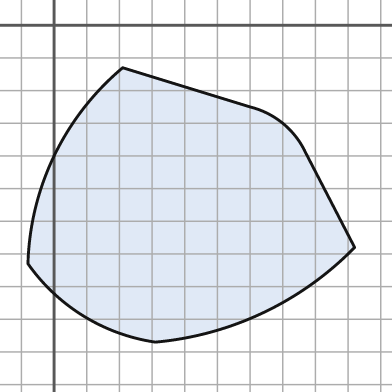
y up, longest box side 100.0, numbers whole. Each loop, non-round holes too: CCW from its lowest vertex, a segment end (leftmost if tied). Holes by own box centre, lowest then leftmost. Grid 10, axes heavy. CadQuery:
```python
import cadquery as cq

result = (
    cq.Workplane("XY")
    .moveTo(31.0, -97.0)
    .threePointArc((64.0, -88.0), (92.0, -68.0))
    .lineTo(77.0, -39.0)
    .threePointArc((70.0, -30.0), (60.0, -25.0))
    .lineTo(21.0, -13.0)
    .threePointArc((0.0, -40.0), (-8.0, -73.0))
    .threePointArc((9.0, -89.0), (31.0, -97.0))
    .close()
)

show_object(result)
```